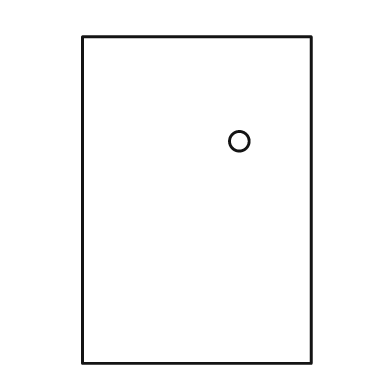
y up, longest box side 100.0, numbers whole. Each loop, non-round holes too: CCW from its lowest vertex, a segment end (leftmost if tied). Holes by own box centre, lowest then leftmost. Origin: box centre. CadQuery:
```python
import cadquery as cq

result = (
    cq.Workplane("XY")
    .moveTo(-35.0, -50.0)
    .lineTo(35.0, -50.0)
    .lineTo(35.0, 50.0)
    .lineTo(-35.0, 50.0)
    .close()
    .moveTo(13.0, 18.0)
    .circle(3.0)
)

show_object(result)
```